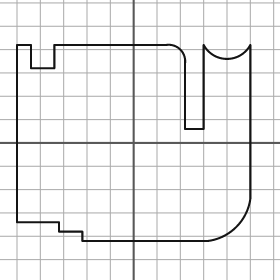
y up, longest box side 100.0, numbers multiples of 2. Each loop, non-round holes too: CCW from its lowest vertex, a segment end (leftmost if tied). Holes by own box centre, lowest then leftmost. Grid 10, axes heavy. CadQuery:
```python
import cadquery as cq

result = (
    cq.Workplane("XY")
    .moveTo(-22.0, -42.0)
    .lineTo(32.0, -42.0)
    .threePointArc((44.0, -36.0), (50.0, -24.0))
    .lineTo(50.0, 42.0)
    .threePointArc((40.0, 36.0), (30.0, 42.0))
    .lineTo(30.0, 6.0)
    .lineTo(22.0, 6.0)
    .lineTo(22.0, 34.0)
    .threePointArc((20.0, 40.0), (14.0, 42.0))
    .lineTo(-34.0, 42.0)
    .lineTo(-34.0, 32.0)
    .lineTo(-44.0, 32.0)
    .lineTo(-44.0, 42.0)
    .lineTo(-50.0, 42.0)
    .lineTo(-50.0, -34.0)
    .lineTo(-32.0, -34.0)
    .lineTo(-32.0, -38.0)
    .lineTo(-22.0, -38.0)
    .close()
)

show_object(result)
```